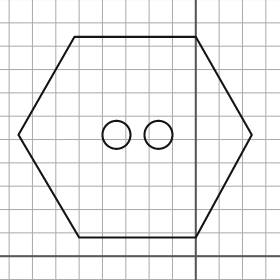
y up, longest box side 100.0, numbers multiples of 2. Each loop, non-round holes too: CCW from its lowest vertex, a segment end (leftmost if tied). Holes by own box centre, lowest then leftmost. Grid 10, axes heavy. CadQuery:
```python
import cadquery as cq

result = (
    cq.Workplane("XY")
    .moveTo(-50.0, 8.0)
    .lineTo(0.0, 8.0)
    .lineTo(24.0, 52.0)
    .lineTo(0.0, 94.0)
    .lineTo(-52.0, 94.0)
    .lineTo(-76.0, 52.0)
    .close()
    .moveTo(-34.0, 52.0)
    .circle(6.0)
    .moveTo(-16.0, 52.0)
    .circle(6.0)
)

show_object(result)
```